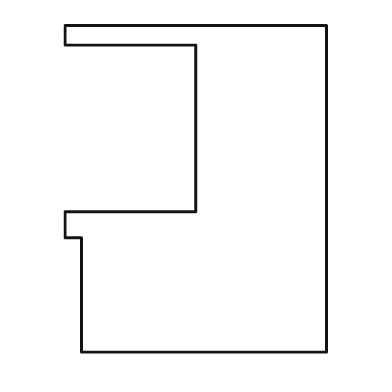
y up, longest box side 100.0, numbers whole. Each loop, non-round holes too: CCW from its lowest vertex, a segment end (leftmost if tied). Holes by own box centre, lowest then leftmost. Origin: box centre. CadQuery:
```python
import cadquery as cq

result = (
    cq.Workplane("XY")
    .moveTo(-35.0, -50.0)
    .lineTo(40.0, -50.0)
    .lineTo(40.0, 50.0)
    .lineTo(-40.0, 50.0)
    .lineTo(-40.0, 44.0)
    .lineTo(0.0, 44.0)
    .lineTo(0.0, -7.0)
    .lineTo(-40.0, -7.0)
    .lineTo(-40.0, -15.0)
    .lineTo(-35.0, -15.0)
    .close()
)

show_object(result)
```